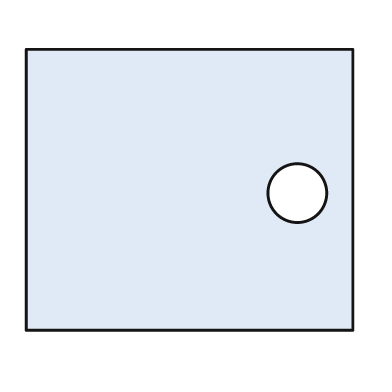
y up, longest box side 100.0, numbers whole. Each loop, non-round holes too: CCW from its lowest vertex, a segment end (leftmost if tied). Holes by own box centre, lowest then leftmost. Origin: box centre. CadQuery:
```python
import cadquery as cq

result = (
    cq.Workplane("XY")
    .moveTo(-50.0, -43.0)
    .lineTo(50.0, -43.0)
    .lineTo(50.0, 43.0)
    .lineTo(-50.0, 43.0)
    .close()
    .moveTo(33.0, -1.0)
    .circle(9.0)
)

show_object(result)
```